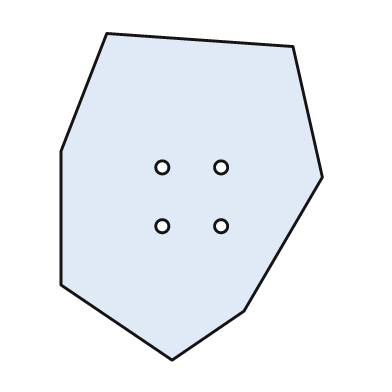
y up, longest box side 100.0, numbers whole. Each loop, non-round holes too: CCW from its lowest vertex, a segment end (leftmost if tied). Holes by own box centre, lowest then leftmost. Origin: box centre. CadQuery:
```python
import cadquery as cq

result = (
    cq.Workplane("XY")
    .moveTo(-6.0, -50.0)
    .lineTo(16.0, -35.0)
    .lineTo(40.0, 6.0)
    .lineTo(31.0, 46.0)
    .lineTo(-26.0, 50.0)
    .lineTo(-40.0, 14.0)
    .lineTo(-40.0, -27.0)
    .close()
    .moveTo(-9.0, -9.0)
    .circle(2.0)
    .moveTo(9.0, -9.0)
    .circle(2.0)
    .moveTo(-9.0, 9.0)
    .circle(2.0)
    .moveTo(9.0, 9.0)
    .circle(2.0)
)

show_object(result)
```